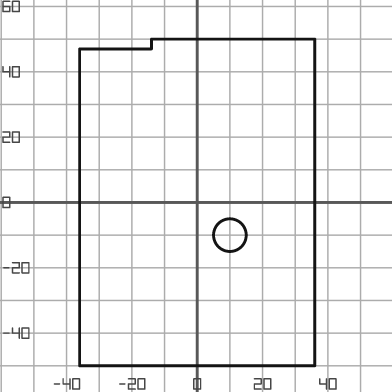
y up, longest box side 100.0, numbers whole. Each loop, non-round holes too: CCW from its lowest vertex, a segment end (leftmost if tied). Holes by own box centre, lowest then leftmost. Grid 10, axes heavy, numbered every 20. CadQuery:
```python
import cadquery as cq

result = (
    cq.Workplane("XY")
    .moveTo(-36.0, -50.0)
    .lineTo(36.0, -50.0)
    .lineTo(36.0, 50.0)
    .lineTo(-14.0, 50.0)
    .lineTo(-14.0, 47.0)
    .lineTo(-36.0, 47.0)
    .close()
    .moveTo(10.0, -10.0)
    .circle(5.0)
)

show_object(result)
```